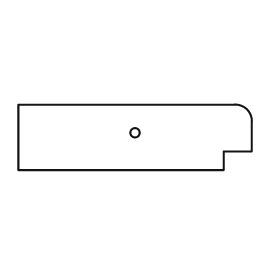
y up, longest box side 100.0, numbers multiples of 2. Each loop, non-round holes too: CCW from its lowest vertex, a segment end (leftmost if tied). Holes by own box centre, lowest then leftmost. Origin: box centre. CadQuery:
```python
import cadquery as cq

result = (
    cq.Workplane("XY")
    .moveTo(-50.0, -14.0)
    .lineTo(38.0, -14.0)
    .lineTo(38.0, -6.0)
    .lineTo(50.0, -6.0)
    .lineTo(50.0, 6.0)
    .threePointArc((48.0, 12.0), (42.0, 14.0))
    .lineTo(-50.0, 14.0)
    .close()
    .moveTo(0.0, 2.0)
    .circle(2.0)
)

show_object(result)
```